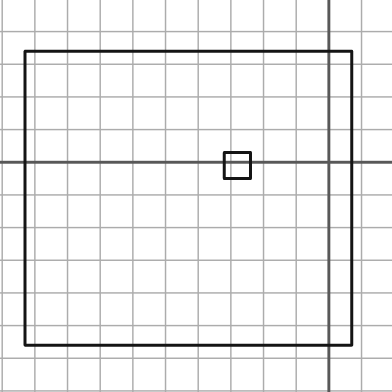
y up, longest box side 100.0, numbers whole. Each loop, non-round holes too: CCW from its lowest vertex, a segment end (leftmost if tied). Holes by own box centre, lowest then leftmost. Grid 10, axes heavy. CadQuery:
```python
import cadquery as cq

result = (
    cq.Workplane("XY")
    .moveTo(-93.0, -56.0)
    .lineTo(7.0, -56.0)
    .lineTo(7.0, 34.0)
    .lineTo(-93.0, 34.0)
    .close()
    .moveTo(-32.0, -5.0)
    .lineTo(-24.0, -5.0)
    .lineTo(-24.0, 3.0)
    .lineTo(-32.0, 3.0)
    .close()
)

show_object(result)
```